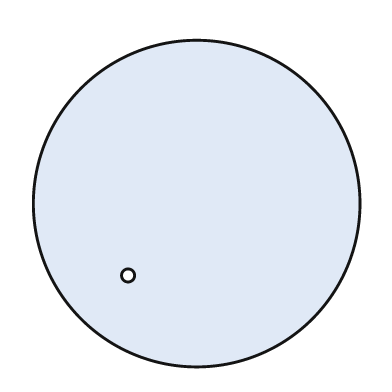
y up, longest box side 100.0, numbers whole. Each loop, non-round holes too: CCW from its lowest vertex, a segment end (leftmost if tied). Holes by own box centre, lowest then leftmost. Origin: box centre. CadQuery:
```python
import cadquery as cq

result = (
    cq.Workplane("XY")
    .moveTo(0.0, 0.0)
    .circle(50.0)
    .moveTo(-21.0, -22.0)
    .circle(2.0)
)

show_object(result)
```